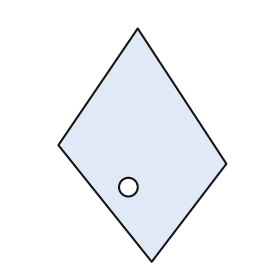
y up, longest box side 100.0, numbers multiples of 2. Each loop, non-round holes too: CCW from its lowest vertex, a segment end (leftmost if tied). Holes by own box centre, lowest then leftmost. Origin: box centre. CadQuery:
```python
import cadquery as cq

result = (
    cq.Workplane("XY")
    .moveTo(4.0, -50.0)
    .lineTo(36.0, -8.0)
    .lineTo(-2.0, 50.0)
    .lineTo(-36.0, 0.0)
    .close()
    .moveTo(-6.0, -18.0)
    .circle(4.0)
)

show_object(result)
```